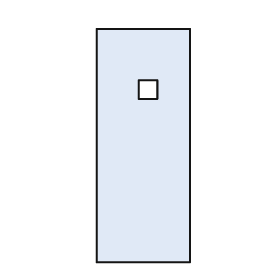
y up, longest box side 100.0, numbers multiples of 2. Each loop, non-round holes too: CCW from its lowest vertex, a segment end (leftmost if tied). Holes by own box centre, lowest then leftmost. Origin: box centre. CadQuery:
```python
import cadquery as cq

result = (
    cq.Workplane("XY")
    .moveTo(-20.0, -50.0)
    .lineTo(20.0, -50.0)
    .lineTo(20.0, 50.0)
    .lineTo(-20.0, 50.0)
    .close()
    .moveTo(-2.0, 20.0)
    .lineTo(6.0, 20.0)
    .lineTo(6.0, 28.0)
    .lineTo(-2.0, 28.0)
    .close()
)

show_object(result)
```